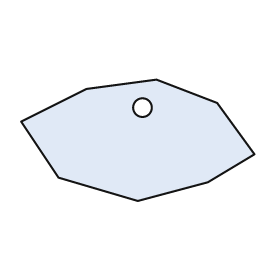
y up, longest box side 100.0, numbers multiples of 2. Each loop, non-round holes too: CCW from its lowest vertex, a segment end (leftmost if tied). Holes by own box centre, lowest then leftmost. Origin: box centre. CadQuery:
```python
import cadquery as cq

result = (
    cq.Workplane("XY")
    .moveTo(0.0, -26.0)
    .lineTo(30.0, -18.0)
    .lineTo(50.0, -6.0)
    .lineTo(34.0, 16.0)
    .lineTo(8.0, 26.0)
    .lineTo(-22.0, 22.0)
    .lineTo(-50.0, 8.0)
    .lineTo(-34.0, -16.0)
    .close()
    .moveTo(2.0, 14.0)
    .circle(4.0)
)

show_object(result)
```